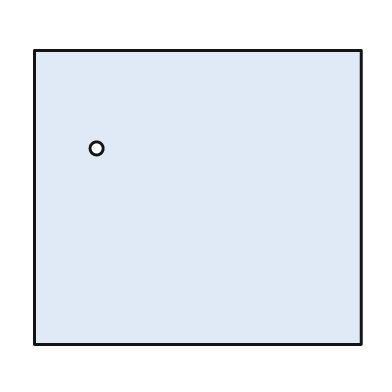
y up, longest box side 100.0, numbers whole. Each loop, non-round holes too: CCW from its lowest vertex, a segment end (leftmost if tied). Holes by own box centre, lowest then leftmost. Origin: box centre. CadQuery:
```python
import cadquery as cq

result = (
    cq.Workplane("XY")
    .moveTo(-50.0, -45.0)
    .lineTo(50.0, -45.0)
    .lineTo(50.0, 45.0)
    .lineTo(-50.0, 45.0)
    .close()
    .moveTo(-31.0, 15.0)
    .circle(2.0)
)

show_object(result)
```